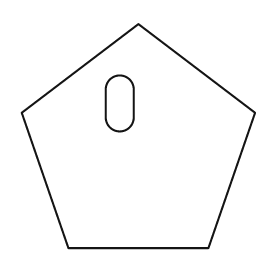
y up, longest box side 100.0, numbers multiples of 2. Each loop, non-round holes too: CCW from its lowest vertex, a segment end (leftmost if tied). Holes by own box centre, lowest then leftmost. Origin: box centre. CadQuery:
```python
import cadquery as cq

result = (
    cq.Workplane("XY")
    .moveTo(-30.0, -48.0)
    .lineTo(30.0, -48.0)
    .lineTo(50.0, 10.0)
    .lineTo(0.0, 48.0)
    .lineTo(-50.0, 10.0)
    .close()
    .moveTo(-14.0, 8.0)
    .threePointArc((-8.0, 2.0), (-2.0, 8.0))
    .lineTo(-2.0, 20.0)
    .threePointArc((-8.0, 26.0), (-14.0, 20.0))
    .close()
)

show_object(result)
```